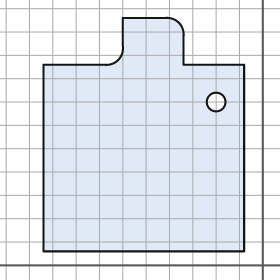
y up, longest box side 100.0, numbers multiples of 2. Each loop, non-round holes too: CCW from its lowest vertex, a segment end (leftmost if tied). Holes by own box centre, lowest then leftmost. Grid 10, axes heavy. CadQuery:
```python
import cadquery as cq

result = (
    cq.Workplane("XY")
    .moveTo(-94.0, 6.0)
    .lineTo(-8.0, 6.0)
    .lineTo(-8.0, 86.0)
    .lineTo(-34.0, 86.0)
    .lineTo(-34.0, 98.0)
    .threePointArc((-36.0, 104.0), (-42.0, 106.0))
    .lineTo(-60.0, 106.0)
    .lineTo(-60.0, 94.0)
    .threePointArc((-62.0, 88.0), (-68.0, 86.0))
    .lineTo(-94.0, 86.0)
    .close()
    .moveTo(-20.0, 70.0)
    .circle(4.0)
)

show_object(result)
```